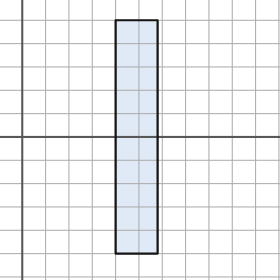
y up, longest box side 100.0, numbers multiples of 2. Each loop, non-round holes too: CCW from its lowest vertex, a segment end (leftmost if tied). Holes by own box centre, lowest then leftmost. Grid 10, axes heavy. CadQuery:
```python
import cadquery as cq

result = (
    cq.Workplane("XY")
    .moveTo(40.0, -50.0)
    .lineTo(58.0, -50.0)
    .lineTo(58.0, 50.0)
    .lineTo(40.0, 50.0)
    .close()
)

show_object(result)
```